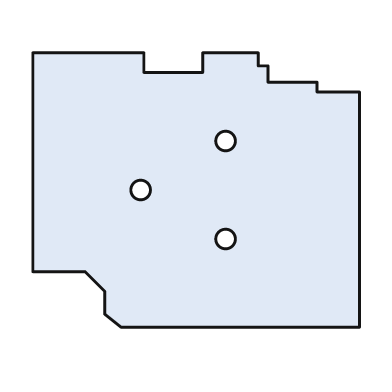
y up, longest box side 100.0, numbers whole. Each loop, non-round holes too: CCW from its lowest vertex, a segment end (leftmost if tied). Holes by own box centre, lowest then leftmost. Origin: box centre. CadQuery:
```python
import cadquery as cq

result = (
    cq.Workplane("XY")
    .moveTo(-23.0, -42.0)
    .lineTo(50.0, -42.0)
    .lineTo(50.0, 30.0)
    .lineTo(37.0, 30.0)
    .lineTo(37.0, 33.0)
    .lineTo(22.0, 33.0)
    .lineTo(22.0, 38.0)
    .lineTo(19.0, 38.0)
    .lineTo(19.0, 42.0)
    .lineTo(2.0, 42.0)
    .lineTo(2.0, 36.0)
    .lineTo(-16.0, 36.0)
    .lineTo(-16.0, 42.0)
    .lineTo(-50.0, 42.0)
    .lineTo(-50.0, -25.0)
    .lineTo(-34.0, -25.0)
    .lineTo(-28.0, -31.0)
    .lineTo(-28.0, -38.0)
    .close()
    .moveTo(9.0, -15.0)
    .circle(3.0)
    .moveTo(-17.0, 0.0)
    .circle(3.0)
    .moveTo(9.0, 15.0)
    .circle(3.0)
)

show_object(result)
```